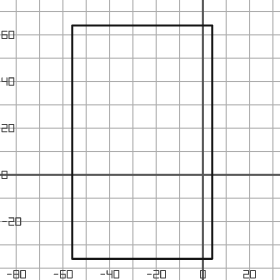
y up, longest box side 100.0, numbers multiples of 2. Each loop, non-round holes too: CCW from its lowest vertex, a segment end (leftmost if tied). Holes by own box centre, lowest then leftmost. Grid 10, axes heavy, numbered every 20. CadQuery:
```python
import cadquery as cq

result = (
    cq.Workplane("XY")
    .moveTo(-56.0, -36.0)
    .lineTo(4.0, -36.0)
    .lineTo(4.0, 64.0)
    .lineTo(-56.0, 64.0)
    .close()
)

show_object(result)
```